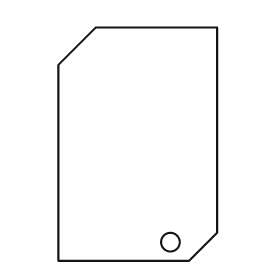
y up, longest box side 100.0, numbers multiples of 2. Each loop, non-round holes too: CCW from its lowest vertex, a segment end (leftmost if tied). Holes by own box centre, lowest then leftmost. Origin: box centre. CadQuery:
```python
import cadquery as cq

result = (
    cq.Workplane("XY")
    .moveTo(-34.0, -50.0)
    .lineTo(22.0, -50.0)
    .lineTo(34.0, -38.0)
    .lineTo(34.0, 50.0)
    .lineTo(-18.0, 50.0)
    .lineTo(-34.0, 34.0)
    .close()
    .moveTo(14.0, -42.0)
    .circle(4.0)
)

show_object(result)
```